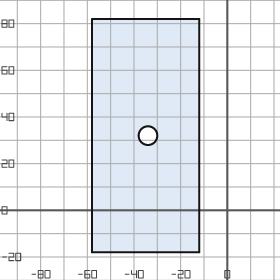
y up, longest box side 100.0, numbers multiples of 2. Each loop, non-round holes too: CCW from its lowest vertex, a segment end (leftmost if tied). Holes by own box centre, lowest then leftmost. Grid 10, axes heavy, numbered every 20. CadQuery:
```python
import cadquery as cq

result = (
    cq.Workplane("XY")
    .moveTo(-58.0, -18.0)
    .lineTo(-12.0, -18.0)
    .lineTo(-12.0, 82.0)
    .lineTo(-58.0, 82.0)
    .close()
    .moveTo(-34.0, 32.0)
    .circle(4.0)
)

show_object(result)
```